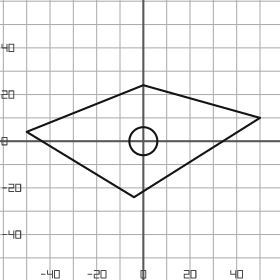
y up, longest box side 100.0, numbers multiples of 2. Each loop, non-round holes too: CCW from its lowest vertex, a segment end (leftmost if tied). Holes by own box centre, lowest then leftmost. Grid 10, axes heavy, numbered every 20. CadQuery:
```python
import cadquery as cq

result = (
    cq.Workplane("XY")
    .moveTo(-4.0, -24.0)
    .lineTo(50.0, 10.0)
    .lineTo(0.0, 24.0)
    .lineTo(-50.0, 4.0)
    .close()
    .moveTo(0.0, 0.0)
    .circle(6.0)
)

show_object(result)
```